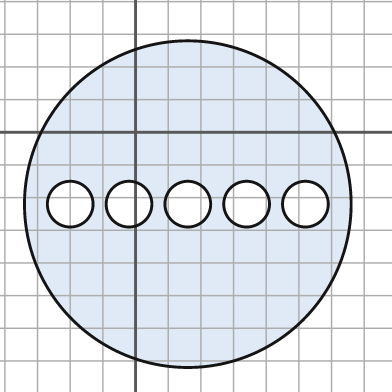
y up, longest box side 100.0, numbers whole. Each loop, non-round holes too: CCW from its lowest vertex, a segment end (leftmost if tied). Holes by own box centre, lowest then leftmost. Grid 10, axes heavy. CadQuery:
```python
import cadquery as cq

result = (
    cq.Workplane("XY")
    .moveTo(16.0, -22.0)
    .circle(50.0)
    .moveTo(-20.0, -22.0)
    .circle(7.0)
    .moveTo(-2.0, -22.0)
    .circle(7.0)
    .moveTo(16.0, -22.0)
    .circle(7.0)
    .moveTo(34.0, -22.0)
    .circle(7.0)
    .moveTo(52.0, -22.0)
    .circle(7.0)
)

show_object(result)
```